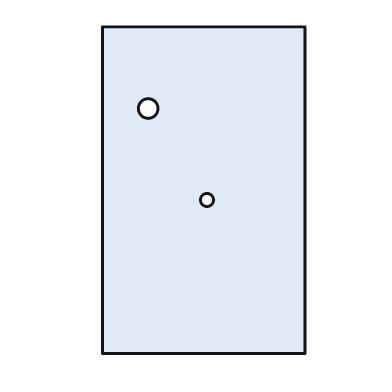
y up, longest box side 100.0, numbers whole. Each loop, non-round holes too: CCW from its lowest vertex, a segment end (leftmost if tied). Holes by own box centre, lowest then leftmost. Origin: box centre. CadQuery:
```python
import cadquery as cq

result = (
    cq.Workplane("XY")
    .moveTo(-31.0, -50.0)
    .lineTo(31.0, -50.0)
    .lineTo(31.0, 50.0)
    .lineTo(-31.0, 50.0)
    .close()
    .moveTo(1.0, -3.0)
    .circle(2.0)
    .moveTo(-17.0, 25.0)
    .circle(3.0)
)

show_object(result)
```